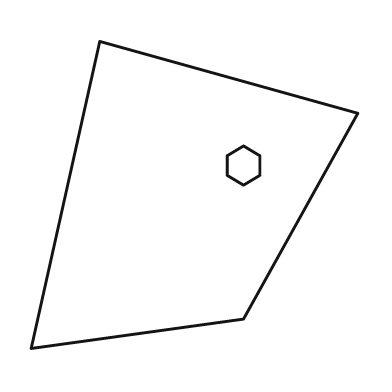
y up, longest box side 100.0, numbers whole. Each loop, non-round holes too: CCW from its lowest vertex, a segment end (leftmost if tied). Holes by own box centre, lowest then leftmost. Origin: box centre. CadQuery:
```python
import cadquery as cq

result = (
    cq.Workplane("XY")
    .moveTo(-50.0, -47.0)
    .lineTo(15.0, -38.0)
    .lineTo(50.0, 25.0)
    .lineTo(-29.0, 47.0)
    .close()
    .moveTo(15.0, 3.0)
    .lineTo(20.0, 6.0)
    .lineTo(20.0, 12.0)
    .lineTo(15.0, 15.0)
    .lineTo(10.0, 12.0)
    .lineTo(10.0, 6.0)
    .close()
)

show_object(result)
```